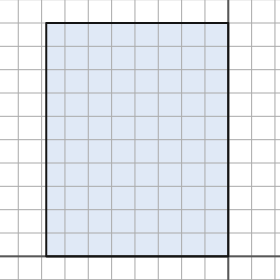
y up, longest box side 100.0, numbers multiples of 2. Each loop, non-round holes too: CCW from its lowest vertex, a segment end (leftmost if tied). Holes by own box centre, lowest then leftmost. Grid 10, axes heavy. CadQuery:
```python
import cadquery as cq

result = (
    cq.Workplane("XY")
    .moveTo(-78.0, 0.0)
    .lineTo(0.0, 0.0)
    .lineTo(0.0, 100.0)
    .lineTo(-78.0, 100.0)
    .close()
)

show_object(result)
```